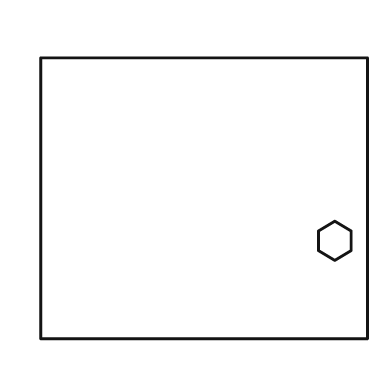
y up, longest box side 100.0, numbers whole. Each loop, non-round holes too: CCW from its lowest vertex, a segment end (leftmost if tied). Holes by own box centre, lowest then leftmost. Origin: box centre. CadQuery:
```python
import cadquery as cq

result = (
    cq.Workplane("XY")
    .moveTo(-50.0, -43.0)
    .lineTo(50.0, -43.0)
    .lineTo(50.0, 43.0)
    .lineTo(-50.0, 43.0)
    .close()
    .moveTo(40.0, -19.0)
    .lineTo(45.0, -16.0)
    .lineTo(45.0, -10.0)
    .lineTo(40.0, -7.0)
    .lineTo(35.0, -10.0)
    .lineTo(35.0, -16.0)
    .close()
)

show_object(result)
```